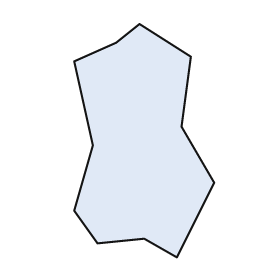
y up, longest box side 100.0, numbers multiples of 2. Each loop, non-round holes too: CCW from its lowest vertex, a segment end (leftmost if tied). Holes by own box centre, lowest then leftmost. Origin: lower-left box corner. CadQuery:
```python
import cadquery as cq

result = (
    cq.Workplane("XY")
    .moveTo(44.0, 0.0)
    .lineTo(60.0, 32.0)
    .lineTo(46.0, 56.0)
    .lineTo(50.0, 86.0)
    .lineTo(28.0, 100.0)
    .lineTo(18.0, 92.0)
    .lineTo(0.0, 84.0)
    .lineTo(8.0, 48.0)
    .lineTo(0.0, 20.0)
    .lineTo(10.0, 6.0)
    .lineTo(30.0, 8.0)
    .close()
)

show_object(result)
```